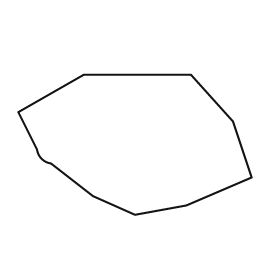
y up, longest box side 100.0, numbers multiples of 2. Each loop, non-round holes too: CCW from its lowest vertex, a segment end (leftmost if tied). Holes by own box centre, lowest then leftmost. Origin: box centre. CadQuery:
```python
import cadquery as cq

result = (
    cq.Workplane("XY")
    .moveTo(0.0, -30.0)
    .lineTo(22.0, -26.0)
    .lineTo(50.0, -14.0)
    .lineTo(42.0, 10.0)
    .lineTo(24.0, 30.0)
    .lineTo(-22.0, 30.0)
    .lineTo(-50.0, 14.0)
    .lineTo(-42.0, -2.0)
    .threePointArc((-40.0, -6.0), (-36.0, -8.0))
    .lineTo(-18.0, -22.0)
    .close()
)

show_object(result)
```